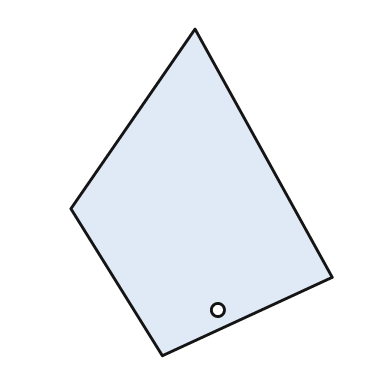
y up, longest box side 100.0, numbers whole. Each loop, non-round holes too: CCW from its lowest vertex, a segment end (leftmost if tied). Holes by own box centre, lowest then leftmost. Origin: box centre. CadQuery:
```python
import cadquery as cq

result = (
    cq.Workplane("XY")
    .moveTo(-12.0, -50.0)
    .lineTo(40.0, -26.0)
    .lineTo(-2.0, 50.0)
    .lineTo(-40.0, -5.0)
    .close()
    .moveTo(5.0, -36.0)
    .circle(2.0)
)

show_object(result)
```